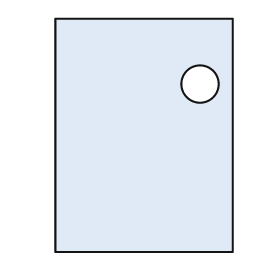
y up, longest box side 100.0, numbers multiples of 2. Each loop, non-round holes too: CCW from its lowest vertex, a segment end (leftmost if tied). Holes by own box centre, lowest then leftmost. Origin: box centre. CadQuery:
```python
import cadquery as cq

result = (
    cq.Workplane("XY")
    .moveTo(-38.0, -50.0)
    .lineTo(38.0, -50.0)
    .lineTo(38.0, 50.0)
    .lineTo(-38.0, 50.0)
    .close()
    .moveTo(24.0, 22.0)
    .circle(8.0)
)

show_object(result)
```